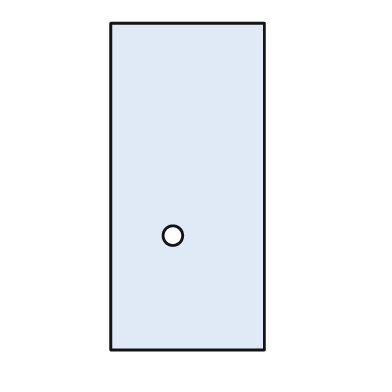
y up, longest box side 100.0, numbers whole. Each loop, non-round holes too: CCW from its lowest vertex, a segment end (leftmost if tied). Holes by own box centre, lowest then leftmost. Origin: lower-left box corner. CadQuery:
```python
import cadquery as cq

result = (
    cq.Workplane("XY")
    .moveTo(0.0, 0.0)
    .lineTo(47.0, 0.0)
    .lineTo(47.0, 100.0)
    .lineTo(0.0, 100.0)
    .close()
    .moveTo(19.0, 35.0)
    .circle(3.0)
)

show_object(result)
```